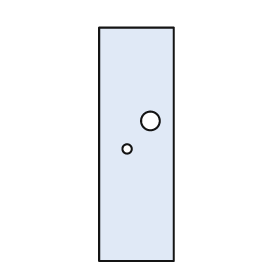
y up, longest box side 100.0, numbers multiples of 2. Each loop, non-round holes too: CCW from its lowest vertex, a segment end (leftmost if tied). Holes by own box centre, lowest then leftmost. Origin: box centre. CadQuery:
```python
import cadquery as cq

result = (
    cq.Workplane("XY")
    .moveTo(-16.0, -50.0)
    .lineTo(16.0, -50.0)
    .lineTo(16.0, 50.0)
    .lineTo(-16.0, 50.0)
    .close()
    .moveTo(-4.0, -2.0)
    .circle(2.0)
    .moveTo(6.0, 10.0)
    .circle(4.0)
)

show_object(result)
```